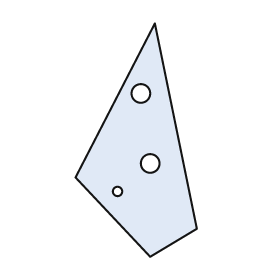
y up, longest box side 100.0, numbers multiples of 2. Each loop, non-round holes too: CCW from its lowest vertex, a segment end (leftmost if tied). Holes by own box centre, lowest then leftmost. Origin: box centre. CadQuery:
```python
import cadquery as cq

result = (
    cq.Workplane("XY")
    .moveTo(6.0, -50.0)
    .lineTo(26.0, -38.0)
    .lineTo(8.0, 50.0)
    .lineTo(-26.0, -16.0)
    .close()
    .moveTo(-8.0, -22.0)
    .circle(2.0)
    .moveTo(6.0, -10.0)
    .circle(4.0)
    .moveTo(2.0, 20.0)
    .circle(4.0)
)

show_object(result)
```